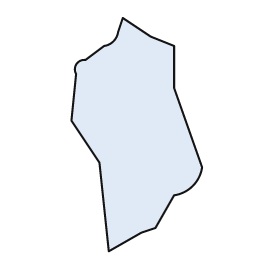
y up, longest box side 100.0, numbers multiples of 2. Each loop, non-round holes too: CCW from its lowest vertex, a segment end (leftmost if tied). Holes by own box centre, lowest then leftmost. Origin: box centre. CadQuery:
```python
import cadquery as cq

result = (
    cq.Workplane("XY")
    .moveTo(-12.0, -50.0)
    .lineTo(2.0, -42.0)
    .lineTo(8.0, -40.0)
    .lineTo(16.0, -26.0)
    .threePointArc((24.0, -22.0), (28.0, -14.0))
    .lineTo(16.0, 20.0)
    .lineTo(16.0, 38.0)
    .lineTo(6.0, 42.0)
    .lineTo(-6.0, 50.0)
    .lineTo(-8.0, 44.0)
    .threePointArc((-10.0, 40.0), (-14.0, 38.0))
    .lineTo(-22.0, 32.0)
    .threePointArc((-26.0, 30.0), (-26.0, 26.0))
    .lineTo(-28.0, 6.0)
    .lineTo(-16.0, -12.0)
    .close()
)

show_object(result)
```